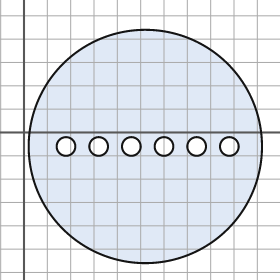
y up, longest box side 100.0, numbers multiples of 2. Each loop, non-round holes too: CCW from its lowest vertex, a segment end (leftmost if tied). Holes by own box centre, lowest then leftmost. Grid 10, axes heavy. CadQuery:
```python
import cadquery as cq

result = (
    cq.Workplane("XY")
    .moveTo(52.0, -6.0)
    .circle(50.0)
    .moveTo(18.0, -6.0)
    .circle(4.0)
    .moveTo(32.0, -6.0)
    .circle(4.0)
    .moveTo(46.0, -6.0)
    .circle(4.0)
    .moveTo(60.0, -6.0)
    .circle(4.0)
    .moveTo(74.0, -6.0)
    .circle(4.0)
    .moveTo(88.0, -6.0)
    .circle(4.0)
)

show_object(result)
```